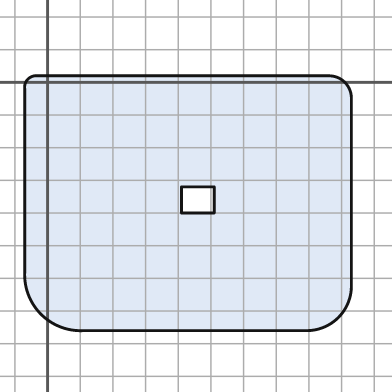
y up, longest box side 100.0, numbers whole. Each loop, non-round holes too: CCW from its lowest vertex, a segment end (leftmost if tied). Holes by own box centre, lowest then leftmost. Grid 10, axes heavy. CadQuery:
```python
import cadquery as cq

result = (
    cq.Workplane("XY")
    .moveTo(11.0, -76.0)
    .lineTo(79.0, -76.0)
    .threePointArc((89.0, -72.0), (93.0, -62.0))
    .lineTo(93.0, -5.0)
    .threePointArc((91.0, 0.0), (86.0, 2.0))
    .lineTo(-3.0, 2.0)
    .threePointArc((-6.0, 1.0), (-7.0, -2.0))
    .lineTo(-7.0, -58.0)
    .threePointArc((-2.0, -71.0), (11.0, -76.0))
    .close()
    .moveTo(41.0, -40.0)
    .lineTo(51.0, -40.0)
    .lineTo(51.0, -32.0)
    .lineTo(41.0, -32.0)
    .close()
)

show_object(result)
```